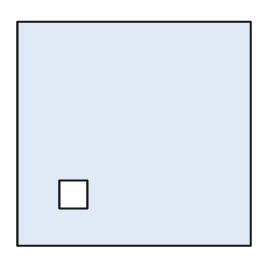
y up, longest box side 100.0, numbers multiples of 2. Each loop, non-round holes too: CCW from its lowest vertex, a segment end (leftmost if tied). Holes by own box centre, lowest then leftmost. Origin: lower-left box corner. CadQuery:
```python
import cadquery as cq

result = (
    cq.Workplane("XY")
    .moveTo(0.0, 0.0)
    .lineTo(100.0, 0.0)
    .lineTo(100.0, 96.0)
    .lineTo(0.0, 96.0)
    .close()
    .moveTo(18.0, 16.0)
    .lineTo(30.0, 16.0)
    .lineTo(30.0, 28.0)
    .lineTo(18.0, 28.0)
    .close()
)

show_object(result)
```